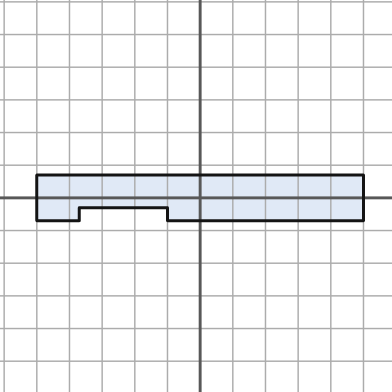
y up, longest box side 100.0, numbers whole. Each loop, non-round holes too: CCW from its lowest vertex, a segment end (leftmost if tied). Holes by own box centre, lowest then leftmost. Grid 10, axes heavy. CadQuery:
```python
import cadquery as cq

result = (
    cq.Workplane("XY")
    .moveTo(-50.0, -7.0)
    .lineTo(-37.0, -7.0)
    .lineTo(-37.0, -3.0)
    .lineTo(-10.0, -3.0)
    .lineTo(-10.0, -7.0)
    .lineTo(50.0, -7.0)
    .lineTo(50.0, 7.0)
    .lineTo(-50.0, 7.0)
    .close()
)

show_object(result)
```